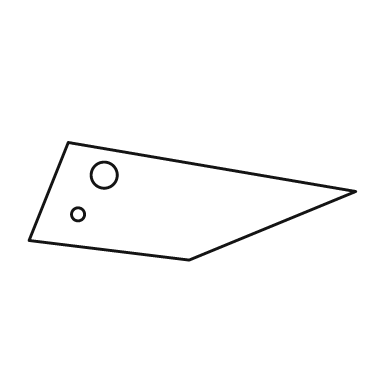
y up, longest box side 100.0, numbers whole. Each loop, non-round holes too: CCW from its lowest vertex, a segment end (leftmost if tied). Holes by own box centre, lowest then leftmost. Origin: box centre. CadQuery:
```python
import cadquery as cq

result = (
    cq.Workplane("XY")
    .moveTo(-1.0, -18.0)
    .lineTo(50.0, 3.0)
    .lineTo(-38.0, 18.0)
    .lineTo(-50.0, -12.0)
    .close()
    .moveTo(-35.0, -4.0)
    .circle(2.0)
    .moveTo(-27.0, 8.0)
    .circle(4.0)
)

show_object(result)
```